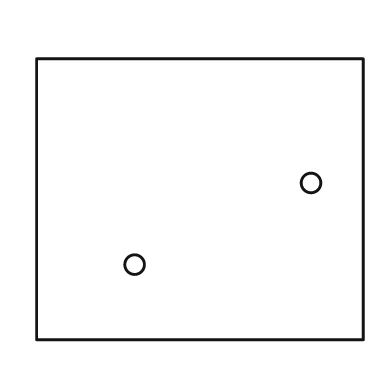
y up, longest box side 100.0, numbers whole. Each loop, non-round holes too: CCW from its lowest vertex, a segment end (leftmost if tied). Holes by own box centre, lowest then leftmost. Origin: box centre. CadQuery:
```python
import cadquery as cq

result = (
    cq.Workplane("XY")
    .moveTo(-50.0, -43.0)
    .lineTo(50.0, -43.0)
    .lineTo(50.0, 43.0)
    .lineTo(-50.0, 43.0)
    .close()
    .moveTo(-20.0, -20.0)
    .circle(3.0)
    .moveTo(34.0, 5.0)
    .circle(3.0)
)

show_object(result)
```